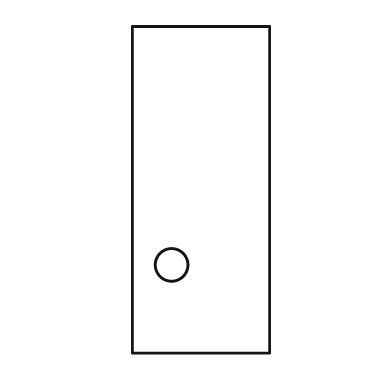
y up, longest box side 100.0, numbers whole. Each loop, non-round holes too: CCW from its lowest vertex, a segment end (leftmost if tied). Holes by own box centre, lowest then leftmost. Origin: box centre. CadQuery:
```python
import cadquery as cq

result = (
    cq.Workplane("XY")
    .moveTo(-21.0, -50.0)
    .lineTo(21.0, -50.0)
    .lineTo(21.0, 50.0)
    .lineTo(-21.0, 50.0)
    .close()
    .moveTo(-9.0, -23.0)
    .circle(5.0)
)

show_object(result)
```